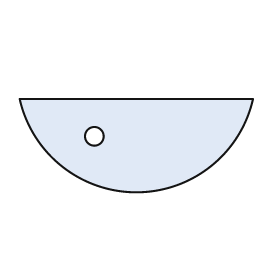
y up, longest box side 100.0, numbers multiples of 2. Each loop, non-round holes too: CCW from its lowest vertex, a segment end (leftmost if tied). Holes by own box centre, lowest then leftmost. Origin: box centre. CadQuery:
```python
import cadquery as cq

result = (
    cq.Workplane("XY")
    .moveTo(-50.0, 20.0)
    .threePointArc((0.0, -20.0), (50.0, 20.0))
    .close()
    .moveTo(-18.0, 4.0)
    .circle(4.0)
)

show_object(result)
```